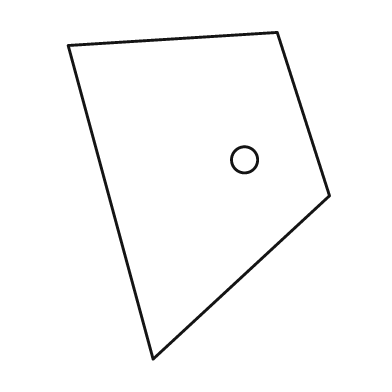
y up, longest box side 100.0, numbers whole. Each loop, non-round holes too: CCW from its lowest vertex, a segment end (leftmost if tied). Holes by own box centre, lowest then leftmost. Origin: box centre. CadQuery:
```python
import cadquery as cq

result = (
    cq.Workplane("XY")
    .moveTo(-14.0, -50.0)
    .lineTo(40.0, 0.0)
    .lineTo(24.0, 50.0)
    .lineTo(-40.0, 46.0)
    .close()
    .moveTo(14.0, 11.0)
    .circle(4.0)
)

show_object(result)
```